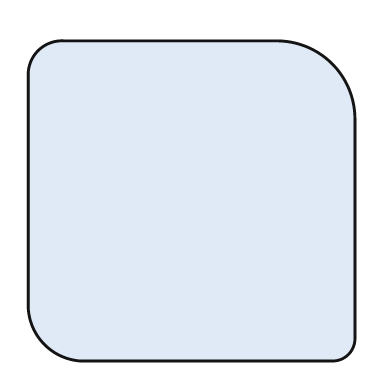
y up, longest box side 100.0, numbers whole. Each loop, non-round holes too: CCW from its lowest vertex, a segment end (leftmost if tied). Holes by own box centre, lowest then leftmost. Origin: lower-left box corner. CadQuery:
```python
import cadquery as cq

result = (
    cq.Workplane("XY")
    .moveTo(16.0, 0.0)
    .lineTo(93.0, 0.0)
    .threePointArc((98.0, 2.0), (100.0, 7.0))
    .lineTo(100.0, 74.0)
    .threePointArc((93.0, 91.0), (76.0, 98.0))
    .lineTo(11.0, 98.0)
    .threePointArc((3.0, 95.0), (0.0, 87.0))
    .lineTo(0.0, 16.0)
    .threePointArc((5.0, 5.0), (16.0, 0.0))
    .close()
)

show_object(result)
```